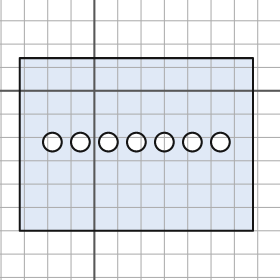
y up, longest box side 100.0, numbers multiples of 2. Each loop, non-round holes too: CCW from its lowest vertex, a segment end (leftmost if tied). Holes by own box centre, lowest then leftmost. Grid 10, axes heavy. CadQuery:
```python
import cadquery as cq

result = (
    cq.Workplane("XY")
    .moveTo(-32.0, -60.0)
    .lineTo(68.0, -60.0)
    .lineTo(68.0, 14.0)
    .lineTo(-32.0, 14.0)
    .close()
    .moveTo(-18.0, -22.0)
    .circle(4.0)
    .moveTo(-6.0, -22.0)
    .circle(4.0)
    .moveTo(6.0, -22.0)
    .circle(4.0)
    .moveTo(18.0, -22.0)
    .circle(4.0)
    .moveTo(30.0, -22.0)
    .circle(4.0)
    .moveTo(42.0, -22.0)
    .circle(4.0)
    .moveTo(54.0, -22.0)
    .circle(4.0)
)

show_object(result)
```